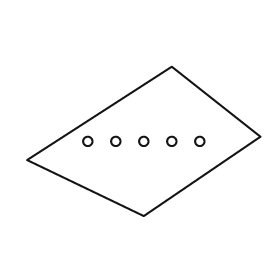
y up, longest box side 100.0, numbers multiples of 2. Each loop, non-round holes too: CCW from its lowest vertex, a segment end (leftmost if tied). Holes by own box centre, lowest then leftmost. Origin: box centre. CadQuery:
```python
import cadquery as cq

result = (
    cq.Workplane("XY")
    .moveTo(0.0, -32.0)
    .lineTo(50.0, 2.0)
    .lineTo(12.0, 32.0)
    .lineTo(-50.0, -8.0)
    .close()
    .moveTo(-24.0, 0.0)
    .circle(2.0)
    .moveTo(-12.0, 0.0)
    .circle(2.0)
    .moveTo(0.0, 0.0)
    .circle(2.0)
    .moveTo(12.0, 0.0)
    .circle(2.0)
    .moveTo(24.0, 0.0)
    .circle(2.0)
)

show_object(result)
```